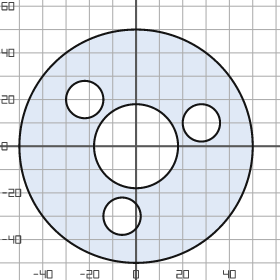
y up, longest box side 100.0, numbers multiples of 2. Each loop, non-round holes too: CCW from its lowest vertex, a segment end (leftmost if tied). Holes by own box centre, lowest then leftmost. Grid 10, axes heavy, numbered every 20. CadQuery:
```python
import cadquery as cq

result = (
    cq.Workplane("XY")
    .moveTo(0.0, 0.0)
    .circle(50.0)
    .moveTo(-6.0, -30.0)
    .circle(8.0)
    .moveTo(0.0, 0.0)
    .circle(18.0)
    .moveTo(28.0, 10.0)
    .circle(8.0)
    .moveTo(-22.0, 20.0)
    .circle(8.0)
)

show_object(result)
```